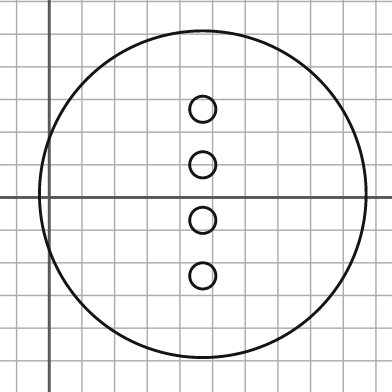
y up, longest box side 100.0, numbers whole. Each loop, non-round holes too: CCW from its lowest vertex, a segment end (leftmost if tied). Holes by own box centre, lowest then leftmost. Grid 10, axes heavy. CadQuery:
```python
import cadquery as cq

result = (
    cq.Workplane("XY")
    .moveTo(47.0, 1.0)
    .circle(50.0)
    .moveTo(47.0, -24.0)
    .circle(4.0)
    .moveTo(47.0, -7.0)
    .circle(4.0)
    .moveTo(47.0, 10.0)
    .circle(4.0)
    .moveTo(47.0, 27.0)
    .circle(4.0)
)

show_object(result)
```